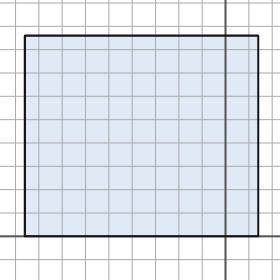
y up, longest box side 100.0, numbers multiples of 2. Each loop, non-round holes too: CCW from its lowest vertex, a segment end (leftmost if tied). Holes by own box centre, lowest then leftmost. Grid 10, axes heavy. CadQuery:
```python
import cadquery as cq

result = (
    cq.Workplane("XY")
    .moveTo(-86.0, 0.0)
    .lineTo(14.0, 0.0)
    .lineTo(14.0, 86.0)
    .lineTo(-86.0, 86.0)
    .close()
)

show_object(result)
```